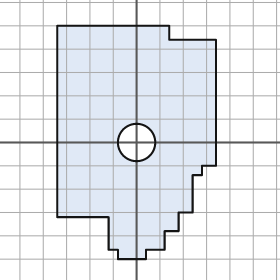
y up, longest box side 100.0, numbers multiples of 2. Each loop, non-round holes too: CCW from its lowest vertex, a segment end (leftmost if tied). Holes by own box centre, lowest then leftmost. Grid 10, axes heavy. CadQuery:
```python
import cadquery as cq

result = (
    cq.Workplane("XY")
    .moveTo(-8.0, -50.0)
    .lineTo(4.0, -50.0)
    .lineTo(4.0, -46.0)
    .lineTo(12.0, -46.0)
    .lineTo(12.0, -38.0)
    .lineTo(18.0, -38.0)
    .lineTo(18.0, -30.0)
    .lineTo(24.0, -30.0)
    .lineTo(24.0, -14.0)
    .lineTo(28.0, -14.0)
    .lineTo(28.0, -10.0)
    .lineTo(34.0, -10.0)
    .lineTo(34.0, 44.0)
    .lineTo(14.0, 44.0)
    .lineTo(14.0, 50.0)
    .lineTo(-34.0, 50.0)
    .lineTo(-34.0, -32.0)
    .lineTo(-12.0, -32.0)
    .lineTo(-12.0, -46.0)
    .lineTo(-8.0, -46.0)
    .close()
    .moveTo(0.0, 0.0)
    .circle(8.0)
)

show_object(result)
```